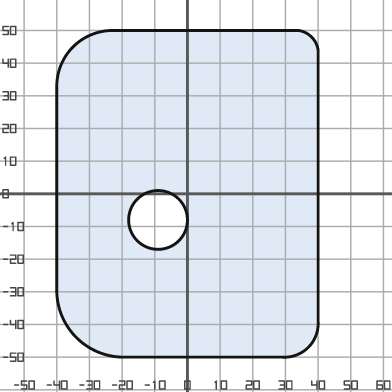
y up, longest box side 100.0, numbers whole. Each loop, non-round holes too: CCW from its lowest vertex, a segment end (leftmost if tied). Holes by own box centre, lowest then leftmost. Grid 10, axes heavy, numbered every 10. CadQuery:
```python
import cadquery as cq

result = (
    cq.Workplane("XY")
    .moveTo(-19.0, -50.0)
    .lineTo(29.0, -50.0)
    .threePointArc((37.0, -47.0), (40.0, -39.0))
    .lineTo(40.0, 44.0)
    .threePointArc((38.0, 48.0), (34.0, 50.0))
    .lineTo(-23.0, 50.0)
    .threePointArc((-35.0, 45.0), (-40.0, 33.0))
    .lineTo(-40.0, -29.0)
    .threePointArc((-34.0, -44.0), (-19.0, -50.0))
    .close()
    .moveTo(-9.0, -8.0)
    .circle(9.0)
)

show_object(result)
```